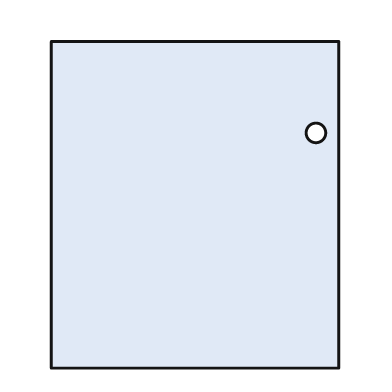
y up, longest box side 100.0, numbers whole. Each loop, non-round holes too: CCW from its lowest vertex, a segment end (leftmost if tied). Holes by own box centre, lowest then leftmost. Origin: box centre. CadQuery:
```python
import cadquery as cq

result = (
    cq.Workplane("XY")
    .moveTo(-44.0, -50.0)
    .lineTo(44.0, -50.0)
    .lineTo(44.0, 50.0)
    .lineTo(-44.0, 50.0)
    .close()
    .moveTo(37.0, 22.0)
    .circle(3.0)
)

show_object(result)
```